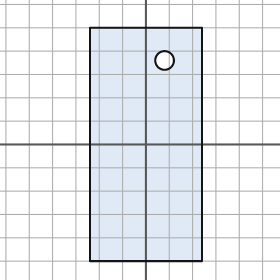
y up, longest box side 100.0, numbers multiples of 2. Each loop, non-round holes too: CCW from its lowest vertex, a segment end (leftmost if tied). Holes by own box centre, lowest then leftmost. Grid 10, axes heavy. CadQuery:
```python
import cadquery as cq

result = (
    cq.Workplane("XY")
    .moveTo(-24.0, -50.0)
    .lineTo(24.0, -50.0)
    .lineTo(24.0, 50.0)
    .lineTo(-24.0, 50.0)
    .close()
    .moveTo(8.0, 36.0)
    .circle(4.0)
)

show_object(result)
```